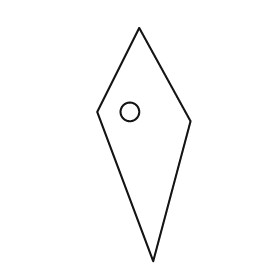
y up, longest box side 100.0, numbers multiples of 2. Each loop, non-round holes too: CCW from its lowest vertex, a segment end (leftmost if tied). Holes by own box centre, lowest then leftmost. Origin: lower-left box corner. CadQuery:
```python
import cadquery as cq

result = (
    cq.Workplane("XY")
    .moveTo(24.0, 0.0)
    .lineTo(40.0, 60.0)
    .lineTo(18.0, 100.0)
    .lineTo(0.0, 64.0)
    .close()
    .moveTo(14.0, 64.0)
    .circle(4.0)
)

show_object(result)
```